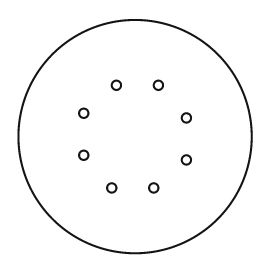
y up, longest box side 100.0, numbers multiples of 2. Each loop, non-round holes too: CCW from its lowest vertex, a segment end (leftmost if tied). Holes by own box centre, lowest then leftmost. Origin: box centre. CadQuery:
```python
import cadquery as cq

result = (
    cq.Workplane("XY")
    .moveTo(0.0, 0.0)
    .circle(50.0)
    .moveTo(-10.0, -22.0)
    .circle(2.0)
    .moveTo(8.0, -22.0)
    .circle(2.0)
    .moveTo(22.0, -10.0)
    .circle(2.0)
    .moveTo(-22.0, -8.0)
    .circle(2.0)
    .moveTo(22.0, 8.0)
    .circle(2.0)
    .moveTo(-22.0, 10.0)
    .circle(2.0)
    .moveTo(-8.0, 22.0)
    .circle(2.0)
    .moveTo(10.0, 22.0)
    .circle(2.0)
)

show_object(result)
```